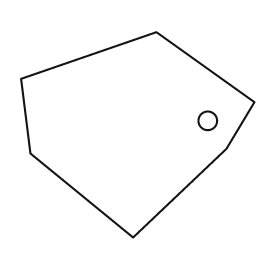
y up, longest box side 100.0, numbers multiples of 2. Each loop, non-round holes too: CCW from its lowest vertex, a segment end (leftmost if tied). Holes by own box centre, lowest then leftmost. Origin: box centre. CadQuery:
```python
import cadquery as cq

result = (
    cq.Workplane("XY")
    .moveTo(-2.0, -44.0)
    .lineTo(38.0, -6.0)
    .lineTo(50.0, 14.0)
    .lineTo(8.0, 44.0)
    .lineTo(-50.0, 24.0)
    .lineTo(-46.0, -8.0)
    .close()
    .moveTo(30.0, 6.0)
    .circle(4.0)
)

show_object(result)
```